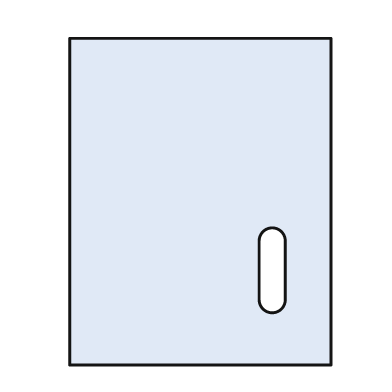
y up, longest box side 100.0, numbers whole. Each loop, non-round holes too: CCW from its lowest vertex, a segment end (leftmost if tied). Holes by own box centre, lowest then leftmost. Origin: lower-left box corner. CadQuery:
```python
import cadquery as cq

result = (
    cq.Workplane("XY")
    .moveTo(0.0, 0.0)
    .lineTo(80.0, 0.0)
    .lineTo(80.0, 100.0)
    .lineTo(0.0, 100.0)
    .close()
    .moveTo(58.0, 20.0)
    .threePointArc((62.0, 16.0), (66.0, 20.0))
    .lineTo(66.0, 38.0)
    .threePointArc((62.0, 42.0), (58.0, 38.0))
    .close()
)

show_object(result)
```